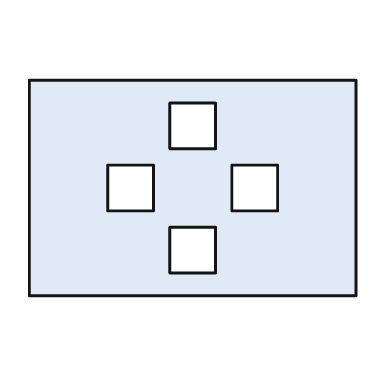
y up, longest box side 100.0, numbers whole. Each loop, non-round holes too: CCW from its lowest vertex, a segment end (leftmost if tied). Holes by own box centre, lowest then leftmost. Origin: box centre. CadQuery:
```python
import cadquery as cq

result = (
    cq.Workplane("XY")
    .moveTo(-50.0, -33.0)
    .lineTo(50.0, -33.0)
    .lineTo(50.0, 33.0)
    .lineTo(-50.0, 33.0)
    .close()
    .moveTo(-7.0, -26.0)
    .lineTo(7.0, -26.0)
    .lineTo(7.0, -12.0)
    .lineTo(-7.0, -12.0)
    .close()
    .moveTo(-26.0, -7.0)
    .lineTo(-12.0, -7.0)
    .lineTo(-12.0, 7.0)
    .lineTo(-26.0, 7.0)
    .close()
    .moveTo(12.0, -7.0)
    .lineTo(26.0, -7.0)
    .lineTo(26.0, 7.0)
    .lineTo(12.0, 7.0)
    .close()
    .moveTo(-7.0, 12.0)
    .lineTo(7.0, 12.0)
    .lineTo(7.0, 26.0)
    .lineTo(-7.0, 26.0)
    .close()
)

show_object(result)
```